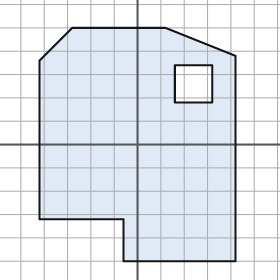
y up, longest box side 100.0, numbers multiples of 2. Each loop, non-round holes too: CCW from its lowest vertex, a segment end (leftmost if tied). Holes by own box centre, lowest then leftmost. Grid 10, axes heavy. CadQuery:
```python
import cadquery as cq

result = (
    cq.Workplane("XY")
    .moveTo(-6.0, -50.0)
    .lineTo(42.0, -50.0)
    .lineTo(42.0, 38.0)
    .lineTo(12.0, 50.0)
    .lineTo(-28.0, 50.0)
    .lineTo(-42.0, 36.0)
    .lineTo(-42.0, -32.0)
    .lineTo(-6.0, -32.0)
    .close()
    .moveTo(16.0, 18.0)
    .lineTo(32.0, 18.0)
    .lineTo(32.0, 34.0)
    .lineTo(16.0, 34.0)
    .close()
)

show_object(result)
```